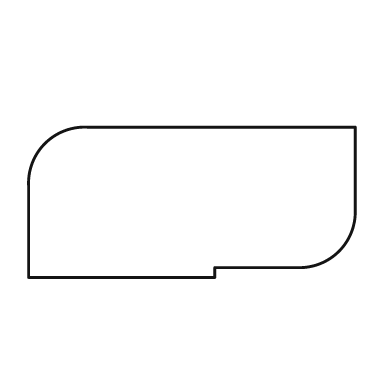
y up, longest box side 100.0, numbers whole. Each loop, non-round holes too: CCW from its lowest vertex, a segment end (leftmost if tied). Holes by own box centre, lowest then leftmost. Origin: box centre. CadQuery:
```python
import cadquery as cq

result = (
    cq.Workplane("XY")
    .moveTo(-50.0, -23.0)
    .lineTo(7.0, -23.0)
    .lineTo(7.0, -20.0)
    .lineTo(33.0, -20.0)
    .threePointArc((45.0, -15.0), (50.0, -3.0))
    .lineTo(50.0, 23.0)
    .lineTo(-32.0, 23.0)
    .threePointArc((-45.0, 18.0), (-50.0, 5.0))
    .close()
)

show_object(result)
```